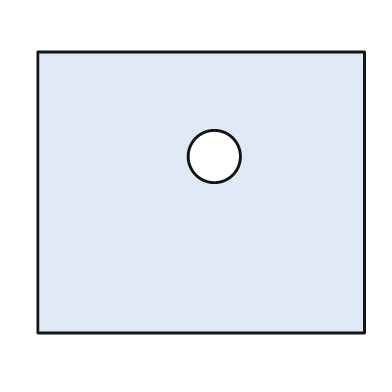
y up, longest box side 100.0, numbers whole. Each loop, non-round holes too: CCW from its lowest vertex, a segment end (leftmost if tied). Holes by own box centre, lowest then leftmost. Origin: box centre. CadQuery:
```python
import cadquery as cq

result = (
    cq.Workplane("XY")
    .moveTo(-50.0, -43.0)
    .lineTo(50.0, -43.0)
    .lineTo(50.0, 43.0)
    .lineTo(-50.0, 43.0)
    .close()
    .moveTo(4.0, 11.0)
    .circle(8.0)
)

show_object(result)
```